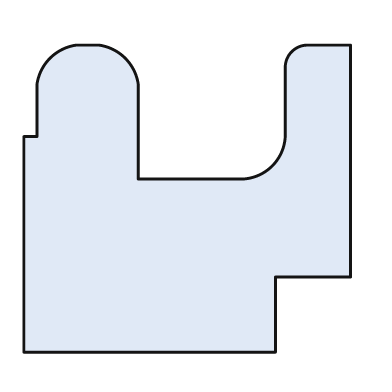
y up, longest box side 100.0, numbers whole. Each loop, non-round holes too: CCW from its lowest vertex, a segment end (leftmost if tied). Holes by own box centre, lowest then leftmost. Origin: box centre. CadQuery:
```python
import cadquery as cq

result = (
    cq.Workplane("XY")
    .moveTo(-50.0, -47.0)
    .lineTo(27.0, -47.0)
    .lineTo(27.0, -24.0)
    .lineTo(50.0, -24.0)
    .lineTo(50.0, 47.0)
    .lineTo(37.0, 47.0)
    .threePointArc((32.0, 45.0), (30.0, 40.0))
    .lineTo(30.0, 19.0)
    .threePointArc((26.0, 10.0), (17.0, 6.0))
    .lineTo(-15.0, 6.0)
    .lineTo(-15.0, 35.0)
    .threePointArc((-19.0, 43.0), (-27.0, 47.0))
    .lineTo(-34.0, 47.0)
    .threePointArc((-42.0, 43.0), (-46.0, 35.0))
    .lineTo(-46.0, 19.0)
    .lineTo(-50.0, 19.0)
    .close()
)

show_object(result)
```